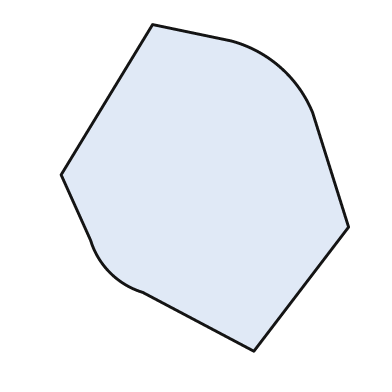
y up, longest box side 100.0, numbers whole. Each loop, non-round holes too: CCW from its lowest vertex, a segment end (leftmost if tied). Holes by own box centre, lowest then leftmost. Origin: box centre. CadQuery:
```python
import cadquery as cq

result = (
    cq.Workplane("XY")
    .moveTo(15.0, -50.0)
    .lineTo(44.0, -12.0)
    .lineTo(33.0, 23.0)
    .threePointArc((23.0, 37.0), (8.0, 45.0))
    .lineTo(-16.0, 50.0)
    .lineTo(-44.0, 4.0)
    .lineTo(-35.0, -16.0)
    .threePointArc((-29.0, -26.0), (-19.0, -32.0))
    .close()
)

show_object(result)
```